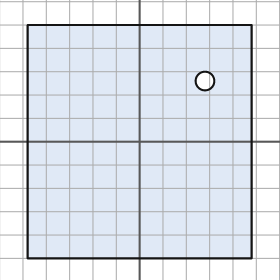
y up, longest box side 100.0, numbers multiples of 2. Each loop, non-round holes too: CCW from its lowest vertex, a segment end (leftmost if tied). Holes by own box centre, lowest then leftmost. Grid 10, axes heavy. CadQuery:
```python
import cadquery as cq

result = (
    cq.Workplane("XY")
    .moveTo(-48.0, -50.0)
    .lineTo(48.0, -50.0)
    .lineTo(48.0, 50.0)
    .lineTo(-48.0, 50.0)
    .close()
    .moveTo(28.0, 26.0)
    .circle(4.0)
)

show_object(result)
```